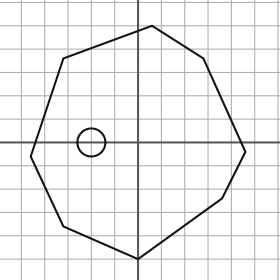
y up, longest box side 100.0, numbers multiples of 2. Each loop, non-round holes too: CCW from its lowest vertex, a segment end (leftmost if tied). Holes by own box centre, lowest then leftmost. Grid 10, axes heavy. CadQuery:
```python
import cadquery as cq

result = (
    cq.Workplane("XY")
    .moveTo(0.0, -50.0)
    .lineTo(36.0, -24.0)
    .lineTo(46.0, -4.0)
    .lineTo(28.0, 36.0)
    .lineTo(6.0, 50.0)
    .lineTo(-32.0, 36.0)
    .lineTo(-46.0, -6.0)
    .lineTo(-32.0, -36.0)
    .close()
    .moveTo(-20.0, 0.0)
    .circle(6.0)
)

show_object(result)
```